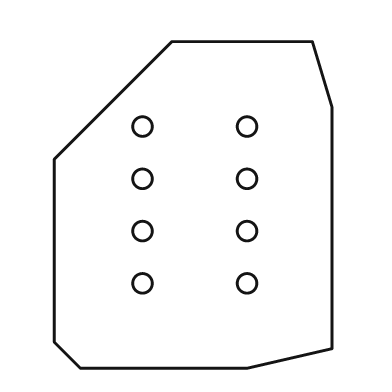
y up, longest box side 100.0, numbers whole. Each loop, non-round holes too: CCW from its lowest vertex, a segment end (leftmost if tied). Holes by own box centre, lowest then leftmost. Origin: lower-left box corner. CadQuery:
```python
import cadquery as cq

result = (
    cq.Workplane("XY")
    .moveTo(8.0, 0.0)
    .lineTo(59.0, 0.0)
    .lineTo(85.0, 6.0)
    .lineTo(85.0, 80.0)
    .lineTo(79.0, 100.0)
    .lineTo(36.0, 100.0)
    .lineTo(0.0, 64.0)
    .lineTo(0.0, 8.0)
    .close()
    .moveTo(27.0, 26.0)
    .circle(3.0)
    .moveTo(59.0, 26.0)
    .circle(3.0)
    .moveTo(27.0, 42.0)
    .circle(3.0)
    .moveTo(59.0, 42.0)
    .circle(3.0)
    .moveTo(27.0, 58.0)
    .circle(3.0)
    .moveTo(59.0, 58.0)
    .circle(3.0)
    .moveTo(27.0, 74.0)
    .circle(3.0)
    .moveTo(59.0, 74.0)
    .circle(3.0)
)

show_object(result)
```